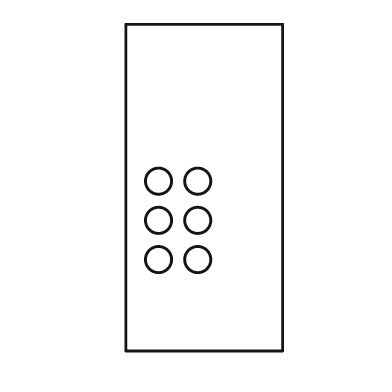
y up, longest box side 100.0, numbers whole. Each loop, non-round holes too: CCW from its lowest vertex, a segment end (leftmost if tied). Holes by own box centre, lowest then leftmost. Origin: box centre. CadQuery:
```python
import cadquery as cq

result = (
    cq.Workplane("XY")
    .moveTo(-24.0, -50.0)
    .lineTo(24.0, -50.0)
    .lineTo(24.0, 50.0)
    .lineTo(-24.0, 50.0)
    .close()
    .moveTo(-14.0, -22.0)
    .circle(4.0)
    .moveTo(-2.0, -22.0)
    .circle(4.0)
    .moveTo(-14.0, -10.0)
    .circle(4.0)
    .moveTo(-2.0, -10.0)
    .circle(4.0)
    .moveTo(-14.0, 2.0)
    .circle(4.0)
    .moveTo(-2.0, 2.0)
    .circle(4.0)
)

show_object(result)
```